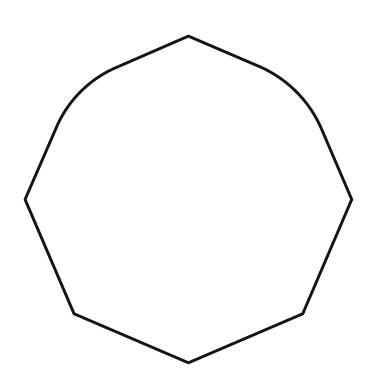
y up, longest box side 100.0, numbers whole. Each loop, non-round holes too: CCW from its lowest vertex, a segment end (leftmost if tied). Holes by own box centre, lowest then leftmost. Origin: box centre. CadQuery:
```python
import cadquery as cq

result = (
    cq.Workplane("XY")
    .moveTo(0.0, -50.0)
    .lineTo(35.0, -35.0)
    .lineTo(50.0, 0.0)
    .lineTo(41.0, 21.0)
    .threePointArc((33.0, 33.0), (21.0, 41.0))
    .lineTo(0.0, 50.0)
    .lineTo(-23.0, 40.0)
    .threePointArc((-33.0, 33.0), (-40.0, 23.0))
    .lineTo(-50.0, 0.0)
    .lineTo(-35.0, -35.0)
    .close()
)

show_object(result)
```